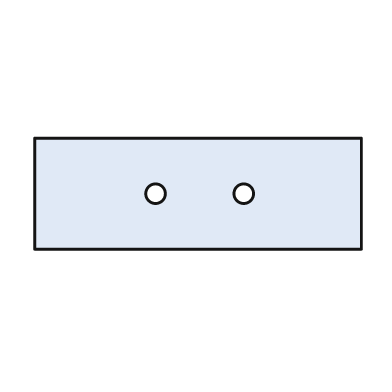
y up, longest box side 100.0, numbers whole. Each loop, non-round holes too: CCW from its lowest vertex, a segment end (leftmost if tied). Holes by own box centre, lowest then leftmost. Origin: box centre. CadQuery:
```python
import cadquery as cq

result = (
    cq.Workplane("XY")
    .moveTo(-50.0, -17.0)
    .lineTo(50.0, -17.0)
    .lineTo(50.0, 17.0)
    .lineTo(-50.0, 17.0)
    .close()
    .moveTo(-13.0, 0.0)
    .circle(3.0)
    .moveTo(14.0, 0.0)
    .circle(3.0)
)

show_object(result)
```